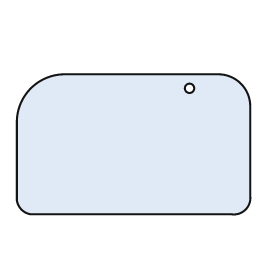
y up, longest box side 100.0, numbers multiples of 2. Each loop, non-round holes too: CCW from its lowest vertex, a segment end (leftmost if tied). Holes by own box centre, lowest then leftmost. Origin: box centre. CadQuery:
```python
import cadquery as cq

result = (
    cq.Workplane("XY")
    .moveTo(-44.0, -30.0)
    .lineTo(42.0, -30.0)
    .threePointArc((48.0, -28.0), (50.0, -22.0))
    .lineTo(50.0, 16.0)
    .threePointArc((46.0, 26.0), (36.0, 30.0))
    .lineTo(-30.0, 30.0)
    .threePointArc((-44.0, 24.0), (-50.0, 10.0))
    .lineTo(-50.0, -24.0)
    .threePointArc((-48.0, -28.0), (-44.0, -30.0))
    .close()
    .moveTo(24.0, 24.0)
    .circle(2.0)
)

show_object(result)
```